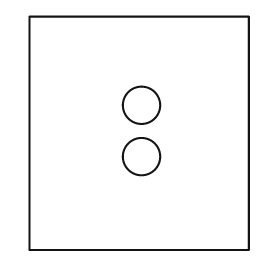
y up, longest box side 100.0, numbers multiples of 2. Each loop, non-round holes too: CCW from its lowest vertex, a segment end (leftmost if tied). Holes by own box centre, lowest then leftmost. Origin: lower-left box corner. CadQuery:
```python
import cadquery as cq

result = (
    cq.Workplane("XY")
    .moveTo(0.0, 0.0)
    .lineTo(94.0, 0.0)
    .lineTo(94.0, 100.0)
    .lineTo(0.0, 100.0)
    .close()
    .moveTo(48.0, 40.0)
    .circle(8.0)
    .moveTo(48.0, 62.0)
    .circle(8.0)
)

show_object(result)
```